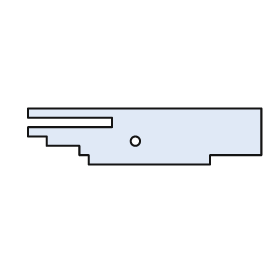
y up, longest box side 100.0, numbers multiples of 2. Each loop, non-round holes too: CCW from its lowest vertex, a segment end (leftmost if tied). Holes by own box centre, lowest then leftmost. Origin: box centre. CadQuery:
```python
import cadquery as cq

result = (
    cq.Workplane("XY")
    .moveTo(-24.0, -12.0)
    .lineTo(28.0, -12.0)
    .lineTo(28.0, -8.0)
    .lineTo(50.0, -8.0)
    .lineTo(50.0, 12.0)
    .lineTo(-50.0, 12.0)
    .lineTo(-50.0, 8.0)
    .lineTo(-14.0, 8.0)
    .lineTo(-14.0, 4.0)
    .lineTo(-50.0, 4.0)
    .lineTo(-50.0, 0.0)
    .lineTo(-42.0, 0.0)
    .lineTo(-42.0, -4.0)
    .lineTo(-28.0, -4.0)
    .lineTo(-28.0, -8.0)
    .lineTo(-24.0, -8.0)
    .close()
    .moveTo(-4.0, -2.0)
    .circle(2.0)
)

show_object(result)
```